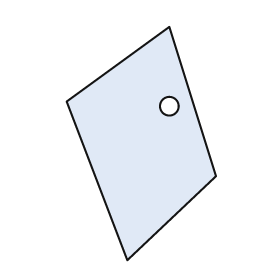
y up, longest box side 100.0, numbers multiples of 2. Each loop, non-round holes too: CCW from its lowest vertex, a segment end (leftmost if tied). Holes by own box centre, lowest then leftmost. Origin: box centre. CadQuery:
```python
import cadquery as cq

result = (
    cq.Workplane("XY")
    .moveTo(-6.0, -50.0)
    .lineTo(32.0, -14.0)
    .lineTo(12.0, 50.0)
    .lineTo(-32.0, 18.0)
    .close()
    .moveTo(12.0, 16.0)
    .circle(4.0)
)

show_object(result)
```